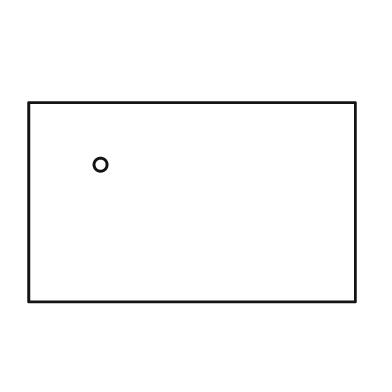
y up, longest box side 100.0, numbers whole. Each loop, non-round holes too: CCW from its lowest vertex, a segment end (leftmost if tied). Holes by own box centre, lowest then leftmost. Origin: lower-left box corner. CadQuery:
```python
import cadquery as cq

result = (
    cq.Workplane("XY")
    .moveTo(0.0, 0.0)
    .lineTo(100.0, 0.0)
    .lineTo(100.0, 61.0)
    .lineTo(0.0, 61.0)
    .close()
    .moveTo(22.0, 42.0)
    .circle(2.0)
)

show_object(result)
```